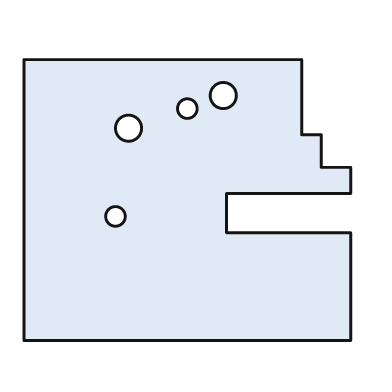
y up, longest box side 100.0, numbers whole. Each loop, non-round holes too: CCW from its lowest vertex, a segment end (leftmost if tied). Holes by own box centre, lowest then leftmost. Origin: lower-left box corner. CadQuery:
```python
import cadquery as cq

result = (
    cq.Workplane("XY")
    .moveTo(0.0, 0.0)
    .lineTo(100.0, 0.0)
    .lineTo(100.0, 33.0)
    .lineTo(62.0, 33.0)
    .lineTo(62.0, 45.0)
    .lineTo(100.0, 45.0)
    .lineTo(100.0, 53.0)
    .lineTo(91.0, 53.0)
    .lineTo(91.0, 63.0)
    .lineTo(85.0, 63.0)
    .lineTo(85.0, 86.0)
    .lineTo(0.0, 86.0)
    .close()
    .moveTo(28.0, 38.0)
    .circle(3.0)
    .moveTo(32.0, 65.0)
    .circle(4.0)
    .moveTo(50.0, 71.0)
    .circle(3.0)
    .moveTo(61.0, 75.0)
    .circle(4.0)
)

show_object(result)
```